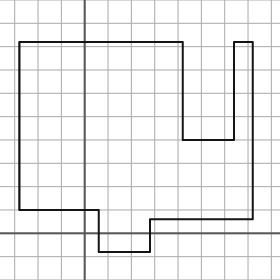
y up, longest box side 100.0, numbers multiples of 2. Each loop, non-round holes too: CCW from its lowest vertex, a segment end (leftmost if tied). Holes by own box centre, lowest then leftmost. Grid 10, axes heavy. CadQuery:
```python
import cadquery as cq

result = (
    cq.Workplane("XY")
    .moveTo(6.0, -8.0)
    .lineTo(28.0, -8.0)
    .lineTo(28.0, 6.0)
    .lineTo(72.0, 6.0)
    .lineTo(72.0, 82.0)
    .lineTo(64.0, 82.0)
    .lineTo(64.0, 40.0)
    .lineTo(42.0, 40.0)
    .lineTo(42.0, 82.0)
    .lineTo(-28.0, 82.0)
    .lineTo(-28.0, 10.0)
    .lineTo(6.0, 10.0)
    .close()
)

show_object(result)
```